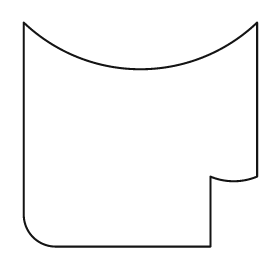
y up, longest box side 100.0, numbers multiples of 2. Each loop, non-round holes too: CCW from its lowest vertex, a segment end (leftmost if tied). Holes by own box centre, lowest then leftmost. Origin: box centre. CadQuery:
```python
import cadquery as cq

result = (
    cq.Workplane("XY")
    .moveTo(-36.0, -48.0)
    .lineTo(30.0, -48.0)
    .lineTo(30.0, -18.0)
    .threePointArc((40.0, -20.0), (50.0, -18.0))
    .lineTo(50.0, 48.0)
    .threePointArc((0.0, 28.0), (-50.0, 48.0))
    .lineTo(-50.0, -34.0)
    .threePointArc((-46.0, -44.0), (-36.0, -48.0))
    .close()
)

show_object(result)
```